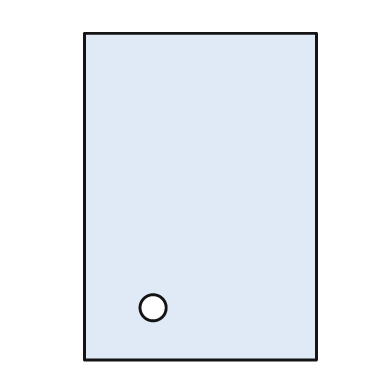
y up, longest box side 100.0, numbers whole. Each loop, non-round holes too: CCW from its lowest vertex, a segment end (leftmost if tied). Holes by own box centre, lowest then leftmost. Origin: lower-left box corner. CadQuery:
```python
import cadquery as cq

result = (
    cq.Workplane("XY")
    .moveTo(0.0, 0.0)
    .lineTo(71.0, 0.0)
    .lineTo(71.0, 100.0)
    .lineTo(0.0, 100.0)
    .close()
    .moveTo(21.0, 16.0)
    .circle(4.0)
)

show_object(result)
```